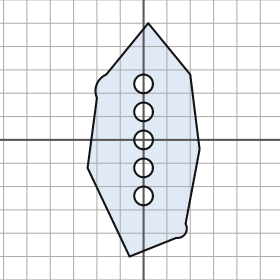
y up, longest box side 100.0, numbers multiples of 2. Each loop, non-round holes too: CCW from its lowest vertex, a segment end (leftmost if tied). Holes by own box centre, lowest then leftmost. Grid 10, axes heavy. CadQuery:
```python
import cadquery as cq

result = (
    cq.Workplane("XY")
    .moveTo(-6.0, -50.0)
    .lineTo(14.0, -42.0)
    .threePointArc((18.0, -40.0), (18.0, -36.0))
    .lineTo(24.0, -4.0)
    .lineTo(20.0, 28.0)
    .lineTo(2.0, 50.0)
    .lineTo(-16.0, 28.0)
    .threePointArc((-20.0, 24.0), (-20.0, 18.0))
    .lineTo(-24.0, -12.0)
    .close()
    .moveTo(0.0, -24.0)
    .circle(4.0)
    .moveTo(0.0, -12.0)
    .circle(4.0)
    .moveTo(0.0, 0.0)
    .circle(4.0)
    .moveTo(0.0, 12.0)
    .circle(4.0)
    .moveTo(0.0, 24.0)
    .circle(4.0)
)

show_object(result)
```